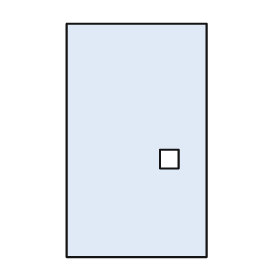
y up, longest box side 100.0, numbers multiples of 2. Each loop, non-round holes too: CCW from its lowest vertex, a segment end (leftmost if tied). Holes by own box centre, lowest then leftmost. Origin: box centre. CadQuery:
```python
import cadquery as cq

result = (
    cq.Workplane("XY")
    .moveTo(-30.0, -50.0)
    .lineTo(30.0, -50.0)
    .lineTo(30.0, 50.0)
    .lineTo(-30.0, 50.0)
    .close()
    .moveTo(10.0, -12.0)
    .lineTo(18.0, -12.0)
    .lineTo(18.0, -4.0)
    .lineTo(10.0, -4.0)
    .close()
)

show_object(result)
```